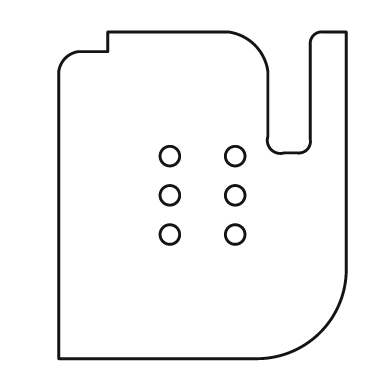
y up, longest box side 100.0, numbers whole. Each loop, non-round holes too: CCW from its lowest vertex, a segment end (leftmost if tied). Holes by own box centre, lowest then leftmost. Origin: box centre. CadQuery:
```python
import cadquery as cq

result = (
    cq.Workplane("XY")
    .moveTo(-44.0, -50.0)
    .lineTo(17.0, -50.0)
    .threePointArc((36.0, -42.0), (44.0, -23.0))
    .lineTo(44.0, 50.0)
    .lineTo(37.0, 50.0)
    .threePointArc((34.0, 49.0), (33.0, 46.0))
    .lineTo(33.0, 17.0)
    .threePointArc((32.0, 14.0), (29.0, 13.0))
    .lineTo(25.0, 13.0)
    .threePointArc((21.0, 14.0), (20.0, 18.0))
    .lineTo(20.0, 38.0)
    .threePointArc((16.0, 46.0), (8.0, 50.0))
    .lineTo(-29.0, 50.0)
    .lineTo(-29.0, 44.0)
    .lineTo(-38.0, 44.0)
    .threePointArc((-42.0, 42.0), (-44.0, 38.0))
    .close()
    .moveTo(-10.0, -12.0)
    .circle(3.0)
    .moveTo(10.0, -12.0)
    .circle(3.0)
    .moveTo(-10.0, 0.0)
    .circle(3.0)
    .moveTo(10.0, 0.0)
    .circle(3.0)
    .moveTo(-10.0, 12.0)
    .circle(3.0)
    .moveTo(10.0, 12.0)
    .circle(3.0)
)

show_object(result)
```